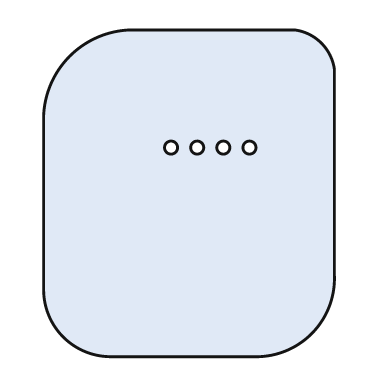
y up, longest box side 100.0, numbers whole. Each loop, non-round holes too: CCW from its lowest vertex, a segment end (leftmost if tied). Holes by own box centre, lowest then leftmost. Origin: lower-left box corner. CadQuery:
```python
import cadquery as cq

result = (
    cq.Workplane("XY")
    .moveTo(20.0, 0.0)
    .lineTo(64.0, 0.0)
    .threePointArc((82.0, 7.0), (89.0, 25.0))
    .lineTo(89.0, 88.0)
    .threePointArc((85.0, 96.0), (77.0, 100.0))
    .lineTo(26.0, 100.0)
    .threePointArc((8.0, 92.0), (0.0, 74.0))
    .lineTo(0.0, 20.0)
    .threePointArc((6.0, 6.0), (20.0, 0.0))
    .close()
    .moveTo(39.0, 64.0)
    .circle(2.0)
    .moveTo(47.0, 64.0)
    .circle(2.0)
    .moveTo(55.0, 64.0)
    .circle(2.0)
    .moveTo(63.0, 64.0)
    .circle(2.0)
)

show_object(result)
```